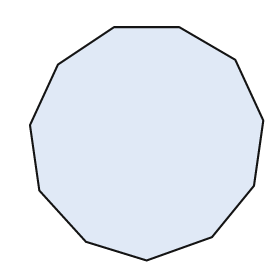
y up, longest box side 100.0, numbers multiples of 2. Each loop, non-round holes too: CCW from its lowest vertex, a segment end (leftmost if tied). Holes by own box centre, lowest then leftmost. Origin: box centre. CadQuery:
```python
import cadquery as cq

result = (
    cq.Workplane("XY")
    .moveTo(0.0, -50.0)
    .lineTo(28.0, -40.0)
    .lineTo(46.0, -18.0)
    .lineTo(50.0, 10.0)
    .lineTo(38.0, 36.0)
    .lineTo(14.0, 50.0)
    .lineTo(-14.0, 50.0)
    .lineTo(-38.0, 34.0)
    .lineTo(-50.0, 8.0)
    .lineTo(-46.0, -20.0)
    .lineTo(-26.0, -42.0)
    .close()
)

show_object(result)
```